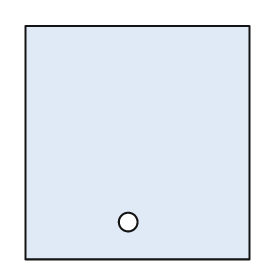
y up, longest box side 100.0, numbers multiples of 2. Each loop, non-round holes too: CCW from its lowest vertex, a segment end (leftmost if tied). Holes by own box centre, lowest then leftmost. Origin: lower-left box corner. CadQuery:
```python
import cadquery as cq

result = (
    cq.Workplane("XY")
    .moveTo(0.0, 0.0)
    .lineTo(96.0, 0.0)
    .lineTo(96.0, 100.0)
    .lineTo(0.0, 100.0)
    .close()
    .moveTo(44.0, 16.0)
    .circle(4.0)
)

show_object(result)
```